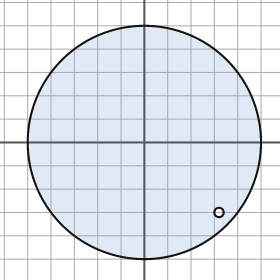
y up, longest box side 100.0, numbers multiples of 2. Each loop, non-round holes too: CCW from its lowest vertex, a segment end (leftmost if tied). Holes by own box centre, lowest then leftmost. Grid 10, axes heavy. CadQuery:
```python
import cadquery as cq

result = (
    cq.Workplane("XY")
    .moveTo(0.0, 0.0)
    .circle(50.0)
    .moveTo(32.0, -30.0)
    .circle(2.0)
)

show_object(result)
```